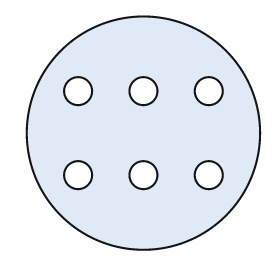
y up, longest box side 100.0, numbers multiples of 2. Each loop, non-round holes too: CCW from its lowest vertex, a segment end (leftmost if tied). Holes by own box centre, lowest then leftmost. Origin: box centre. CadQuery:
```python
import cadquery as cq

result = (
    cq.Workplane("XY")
    .moveTo(0.0, 0.0)
    .circle(50.0)
    .moveTo(-28.0, -18.0)
    .circle(6.0)
    .moveTo(0.0, -18.0)
    .circle(6.0)
    .moveTo(28.0, -18.0)
    .circle(6.0)
    .moveTo(-28.0, 18.0)
    .circle(6.0)
    .moveTo(0.0, 18.0)
    .circle(6.0)
    .moveTo(28.0, 18.0)
    .circle(6.0)
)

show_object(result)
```